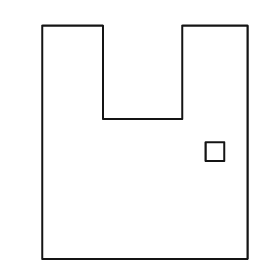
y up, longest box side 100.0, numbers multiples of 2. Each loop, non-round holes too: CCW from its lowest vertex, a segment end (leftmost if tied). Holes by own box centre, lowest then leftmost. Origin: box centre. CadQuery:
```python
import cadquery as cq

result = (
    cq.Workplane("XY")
    .moveTo(-44.0, -50.0)
    .lineTo(44.0, -50.0)
    .lineTo(44.0, 50.0)
    .lineTo(16.0, 50.0)
    .lineTo(16.0, 10.0)
    .lineTo(-18.0, 10.0)
    .lineTo(-18.0, 50.0)
    .lineTo(-44.0, 50.0)
    .close()
    .moveTo(26.0, -8.0)
    .lineTo(34.0, -8.0)
    .lineTo(34.0, 0.0)
    .lineTo(26.0, 0.0)
    .close()
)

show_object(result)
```